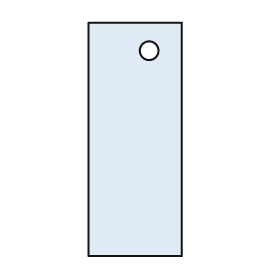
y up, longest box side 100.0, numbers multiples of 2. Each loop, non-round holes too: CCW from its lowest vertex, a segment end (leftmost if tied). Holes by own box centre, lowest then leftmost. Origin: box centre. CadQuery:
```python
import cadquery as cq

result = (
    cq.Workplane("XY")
    .moveTo(-20.0, -50.0)
    .lineTo(20.0, -50.0)
    .lineTo(20.0, 50.0)
    .lineTo(-20.0, 50.0)
    .close()
    .moveTo(6.0, 38.0)
    .circle(4.0)
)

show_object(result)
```